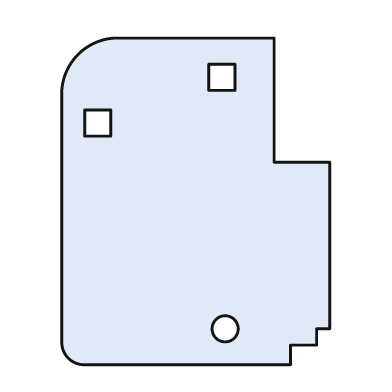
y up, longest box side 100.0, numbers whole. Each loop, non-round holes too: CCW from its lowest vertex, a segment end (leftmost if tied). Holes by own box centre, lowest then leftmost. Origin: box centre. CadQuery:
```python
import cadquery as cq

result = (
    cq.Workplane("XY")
    .moveTo(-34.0, -50.0)
    .lineTo(29.0, -50.0)
    .lineTo(29.0, -44.0)
    .lineTo(37.0, -44.0)
    .lineTo(37.0, -39.0)
    .lineTo(41.0, -39.0)
    .lineTo(41.0, 12.0)
    .lineTo(24.0, 12.0)
    .lineTo(24.0, 50.0)
    .lineTo(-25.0, 50.0)
    .threePointArc((-36.0, 45.0), (-41.0, 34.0))
    .lineTo(-41.0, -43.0)
    .threePointArc((-39.0, -48.0), (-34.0, -50.0))
    .close()
    .moveTo(9.0, -39.0)
    .circle(4.0)
    .moveTo(-34.0, 20.0)
    .lineTo(-26.0, 20.0)
    .lineTo(-26.0, 28.0)
    .lineTo(-34.0, 28.0)
    .close()
    .moveTo(4.0, 34.0)
    .lineTo(12.0, 34.0)
    .lineTo(12.0, 42.0)
    .lineTo(4.0, 42.0)
    .close()
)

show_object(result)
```